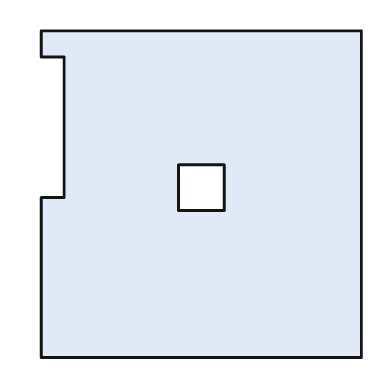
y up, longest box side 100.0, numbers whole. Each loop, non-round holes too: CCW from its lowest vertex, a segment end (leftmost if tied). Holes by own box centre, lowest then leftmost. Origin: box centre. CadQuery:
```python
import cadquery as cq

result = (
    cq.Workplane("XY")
    .moveTo(-49.0, -50.0)
    .lineTo(49.0, -50.0)
    .lineTo(49.0, 50.0)
    .lineTo(-49.0, 50.0)
    .lineTo(-49.0, 42.0)
    .lineTo(-42.0, 42.0)
    .lineTo(-42.0, -1.0)
    .lineTo(-49.0, -1.0)
    .close()
    .moveTo(-7.0, -5.0)
    .lineTo(7.0, -5.0)
    .lineTo(7.0, 9.0)
    .lineTo(-7.0, 9.0)
    .close()
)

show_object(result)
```